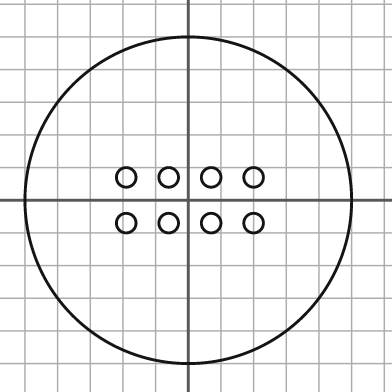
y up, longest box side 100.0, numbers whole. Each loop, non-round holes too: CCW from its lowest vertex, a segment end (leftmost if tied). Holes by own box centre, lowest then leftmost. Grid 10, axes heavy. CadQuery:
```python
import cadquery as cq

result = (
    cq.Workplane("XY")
    .moveTo(0.0, 0.0)
    .circle(50.0)
    .moveTo(-19.0, -7.0)
    .circle(3.0)
    .moveTo(-6.0, -7.0)
    .circle(3.0)
    .moveTo(7.0, -7.0)
    .circle(3.0)
    .moveTo(20.0, -7.0)
    .circle(3.0)
    .moveTo(-19.0, 7.0)
    .circle(3.0)
    .moveTo(-6.0, 7.0)
    .circle(3.0)
    .moveTo(7.0, 7.0)
    .circle(3.0)
    .moveTo(20.0, 7.0)
    .circle(3.0)
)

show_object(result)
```